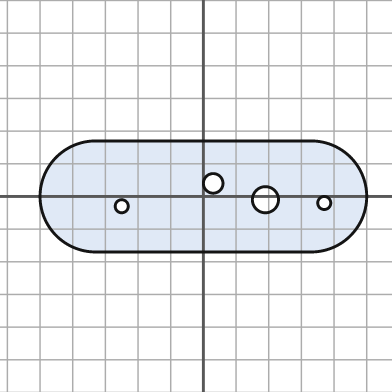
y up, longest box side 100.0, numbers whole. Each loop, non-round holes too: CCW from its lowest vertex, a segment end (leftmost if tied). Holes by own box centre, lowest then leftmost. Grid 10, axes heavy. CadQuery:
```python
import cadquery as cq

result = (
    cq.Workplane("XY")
    .moveTo(-33.0, -17.0)
    .lineTo(33.0, -17.0)
    .threePointArc((50.0, 0.0), (33.0, 17.0))
    .lineTo(-33.0, 17.0)
    .threePointArc((-50.0, 0.0), (-33.0, -17.0))
    .close()
    .moveTo(-25.0, -3.0)
    .circle(2.0)
    .moveTo(37.0, -2.0)
    .circle(2.0)
    .moveTo(19.0, -1.0)
    .circle(4.0)
    .moveTo(3.0, 4.0)
    .circle(3.0)
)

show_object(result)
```